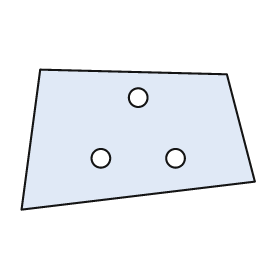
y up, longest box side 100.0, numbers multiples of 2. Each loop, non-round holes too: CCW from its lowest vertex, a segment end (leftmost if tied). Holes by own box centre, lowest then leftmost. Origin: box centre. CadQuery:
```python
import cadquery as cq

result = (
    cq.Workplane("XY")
    .moveTo(-50.0, -30.0)
    .lineTo(50.0, -18.0)
    .lineTo(38.0, 28.0)
    .lineTo(-42.0, 30.0)
    .close()
    .moveTo(-16.0, -8.0)
    .circle(4.0)
    .moveTo(16.0, -8.0)
    .circle(4.0)
    .moveTo(0.0, 18.0)
    .circle(4.0)
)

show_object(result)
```